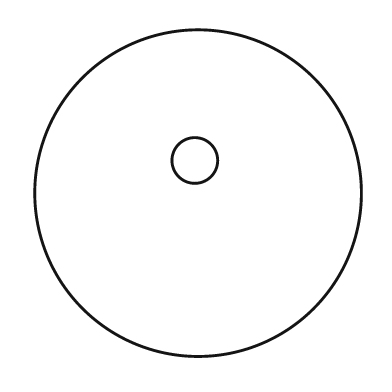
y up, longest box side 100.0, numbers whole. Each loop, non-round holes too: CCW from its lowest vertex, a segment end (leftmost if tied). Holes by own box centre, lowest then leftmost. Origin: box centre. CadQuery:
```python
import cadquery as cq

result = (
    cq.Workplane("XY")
    .moveTo(0.0, 0.0)
    .circle(50.0)
    .moveTo(-1.0, 10.0)
    .circle(7.0)
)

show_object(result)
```